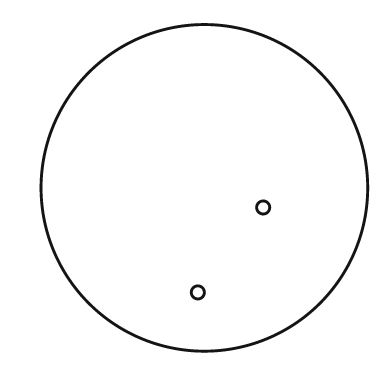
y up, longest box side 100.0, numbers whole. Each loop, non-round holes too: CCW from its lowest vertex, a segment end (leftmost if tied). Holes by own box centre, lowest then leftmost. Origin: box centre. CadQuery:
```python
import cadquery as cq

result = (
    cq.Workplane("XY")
    .moveTo(0.0, 0.0)
    .circle(50.0)
    .moveTo(-2.0, -32.0)
    .circle(2.0)
    .moveTo(18.0, -6.0)
    .circle(2.0)
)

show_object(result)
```